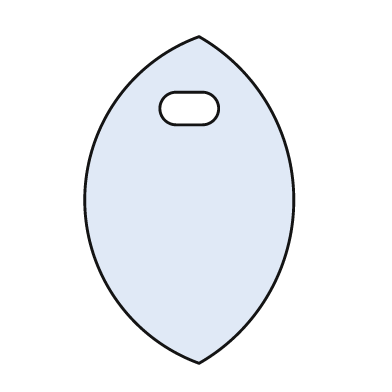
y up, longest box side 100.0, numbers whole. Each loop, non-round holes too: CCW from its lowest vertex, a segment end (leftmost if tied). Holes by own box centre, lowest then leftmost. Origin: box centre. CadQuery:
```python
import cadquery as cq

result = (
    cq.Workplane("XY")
    .moveTo(3.0, -50.0)
    .threePointArc((32.0, 0.0), (3.0, 50.0))
    .threePointArc((-32.0, 0.0), (3.0, -50.0))
    .close()
    .moveTo(-4.0, 23.0)
    .lineTo(4.0, 23.0)
    .threePointArc((9.0, 28.0), (4.0, 33.0))
    .lineTo(-4.0, 33.0)
    .threePointArc((-9.0, 28.0), (-4.0, 23.0))
    .close()
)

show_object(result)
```